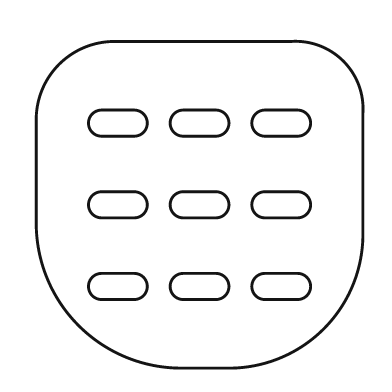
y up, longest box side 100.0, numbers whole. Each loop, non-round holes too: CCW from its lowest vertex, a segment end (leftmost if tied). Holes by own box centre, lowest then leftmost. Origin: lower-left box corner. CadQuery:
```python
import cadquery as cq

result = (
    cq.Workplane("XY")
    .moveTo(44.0, 0.0)
    .lineTo(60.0, 0.0)
    .threePointArc((88.0, 12.0), (100.0, 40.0))
    .lineTo(100.0, 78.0)
    .threePointArc((94.0, 94.0), (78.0, 100.0))
    .lineTo(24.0, 100.0)
    .threePointArc((7.0, 93.0), (0.0, 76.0))
    .lineTo(0.0, 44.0)
    .threePointArc((13.0, 13.0), (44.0, 0.0))
    .close()
    .moveTo(20.0, 21.0)
    .lineTo(30.0, 21.0)
    .threePointArc((34.0, 25.0), (30.0, 29.0))
    .lineTo(20.0, 29.0)
    .threePointArc((16.0, 25.0), (20.0, 21.0))
    .close()
    .moveTo(45.0, 21.0)
    .lineTo(55.0, 21.0)
    .threePointArc((59.0, 25.0), (55.0, 29.0))
    .lineTo(45.0, 29.0)
    .threePointArc((41.0, 25.0), (45.0, 21.0))
    .close()
    .moveTo(70.0, 21.0)
    .lineTo(80.0, 21.0)
    .threePointArc((84.0, 25.0), (80.0, 29.0))
    .lineTo(70.0, 29.0)
    .threePointArc((66.0, 25.0), (70.0, 21.0))
    .close()
    .moveTo(20.0, 46.0)
    .lineTo(30.0, 46.0)
    .threePointArc((34.0, 50.0), (30.0, 54.0))
    .lineTo(20.0, 54.0)
    .threePointArc((16.0, 50.0), (20.0, 46.0))
    .close()
    .moveTo(45.0, 46.0)
    .lineTo(55.0, 46.0)
    .threePointArc((59.0, 50.0), (55.0, 54.0))
    .lineTo(45.0, 54.0)
    .threePointArc((41.0, 50.0), (45.0, 46.0))
    .close()
    .moveTo(70.0, 46.0)
    .lineTo(80.0, 46.0)
    .threePointArc((84.0, 50.0), (80.0, 54.0))
    .lineTo(70.0, 54.0)
    .threePointArc((66.0, 50.0), (70.0, 46.0))
    .close()
    .moveTo(20.0, 71.0)
    .lineTo(30.0, 71.0)
    .threePointArc((34.0, 75.0), (30.0, 79.0))
    .lineTo(20.0, 79.0)
    .threePointArc((16.0, 75.0), (20.0, 71.0))
    .close()
    .moveTo(45.0, 71.0)
    .lineTo(55.0, 71.0)
    .threePointArc((59.0, 75.0), (55.0, 79.0))
    .lineTo(45.0, 79.0)
    .threePointArc((41.0, 75.0), (45.0, 71.0))
    .close()
    .moveTo(70.0, 71.0)
    .lineTo(80.0, 71.0)
    .threePointArc((84.0, 75.0), (80.0, 79.0))
    .lineTo(70.0, 79.0)
    .threePointArc((66.0, 75.0), (70.0, 71.0))
    .close()
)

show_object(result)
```